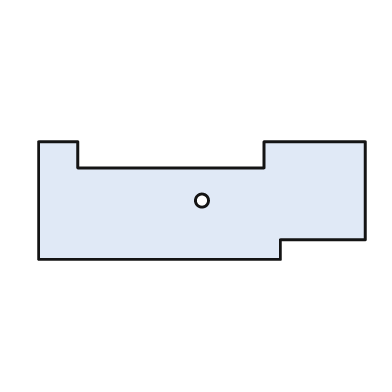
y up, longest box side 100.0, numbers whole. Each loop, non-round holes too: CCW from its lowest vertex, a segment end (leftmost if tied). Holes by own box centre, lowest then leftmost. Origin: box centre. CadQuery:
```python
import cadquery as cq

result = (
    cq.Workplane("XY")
    .moveTo(-50.0, -18.0)
    .lineTo(24.0, -18.0)
    .lineTo(24.0, -12.0)
    .lineTo(50.0, -12.0)
    .lineTo(50.0, 18.0)
    .lineTo(19.0, 18.0)
    .lineTo(19.0, 10.0)
    .lineTo(-38.0, 10.0)
    .lineTo(-38.0, 18.0)
    .lineTo(-50.0, 18.0)
    .close()
    .moveTo(0.0, 0.0)
    .circle(2.0)
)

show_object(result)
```